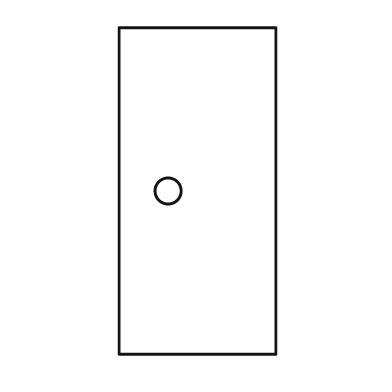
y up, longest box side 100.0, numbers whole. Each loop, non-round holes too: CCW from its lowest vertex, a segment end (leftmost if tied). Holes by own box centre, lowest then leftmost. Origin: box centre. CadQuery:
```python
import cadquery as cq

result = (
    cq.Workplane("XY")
    .moveTo(-24.0, -50.0)
    .lineTo(24.0, -50.0)
    .lineTo(24.0, 50.0)
    .lineTo(-24.0, 50.0)
    .close()
    .moveTo(-9.0, 0.0)
    .circle(4.0)
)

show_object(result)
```